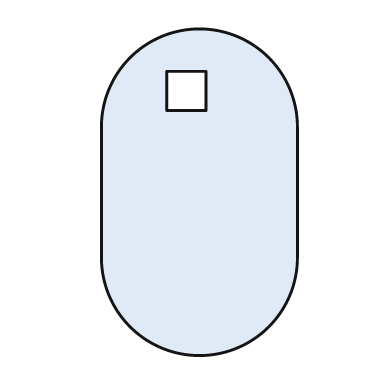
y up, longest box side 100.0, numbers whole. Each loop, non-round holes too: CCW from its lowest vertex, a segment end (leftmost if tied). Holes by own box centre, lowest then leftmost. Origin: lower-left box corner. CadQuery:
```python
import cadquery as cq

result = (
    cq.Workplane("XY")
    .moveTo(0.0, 30.0)
    .threePointArc((30.0, 0.0), (60.0, 30.0))
    .lineTo(60.0, 70.0)
    .threePointArc((30.0, 100.0), (0.0, 70.0))
    .close()
    .moveTo(20.0, 75.0)
    .lineTo(32.0, 75.0)
    .lineTo(32.0, 87.0)
    .lineTo(20.0, 87.0)
    .close()
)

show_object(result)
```